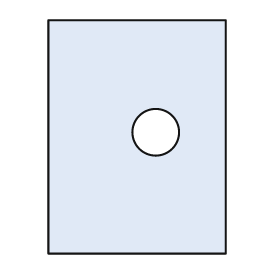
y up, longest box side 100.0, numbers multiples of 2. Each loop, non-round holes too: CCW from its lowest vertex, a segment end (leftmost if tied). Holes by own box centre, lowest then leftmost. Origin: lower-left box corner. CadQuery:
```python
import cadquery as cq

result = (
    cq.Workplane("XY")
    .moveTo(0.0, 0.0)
    .lineTo(76.0, 0.0)
    .lineTo(76.0, 100.0)
    .lineTo(0.0, 100.0)
    .close()
    .moveTo(46.0, 52.0)
    .circle(10.0)
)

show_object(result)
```